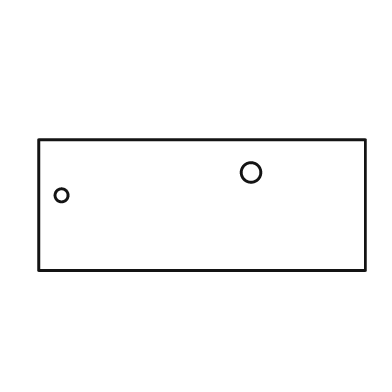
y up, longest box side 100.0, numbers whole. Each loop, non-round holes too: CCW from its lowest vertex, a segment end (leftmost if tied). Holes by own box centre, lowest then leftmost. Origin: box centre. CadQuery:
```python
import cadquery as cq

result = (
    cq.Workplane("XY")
    .moveTo(-50.0, -20.0)
    .lineTo(50.0, -20.0)
    .lineTo(50.0, 20.0)
    .lineTo(-50.0, 20.0)
    .close()
    .moveTo(-43.0, 3.0)
    .circle(2.0)
    .moveTo(15.0, 10.0)
    .circle(3.0)
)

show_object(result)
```